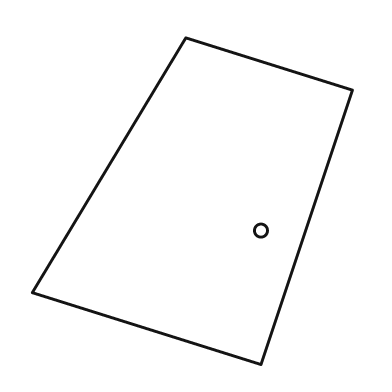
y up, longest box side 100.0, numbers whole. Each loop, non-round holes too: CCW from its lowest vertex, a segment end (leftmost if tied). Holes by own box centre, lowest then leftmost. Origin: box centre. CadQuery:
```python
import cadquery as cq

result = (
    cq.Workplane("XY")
    .moveTo(21.0, -50.0)
    .lineTo(49.0, 34.0)
    .lineTo(-2.0, 50.0)
    .lineTo(-49.0, -28.0)
    .close()
    .moveTo(21.0, -9.0)
    .circle(2.0)
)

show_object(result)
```